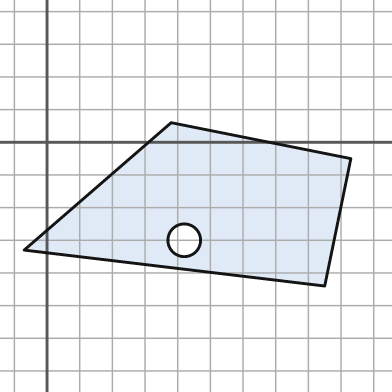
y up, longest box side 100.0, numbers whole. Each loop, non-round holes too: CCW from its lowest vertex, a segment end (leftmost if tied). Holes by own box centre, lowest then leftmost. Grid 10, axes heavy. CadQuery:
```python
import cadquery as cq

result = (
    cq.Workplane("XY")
    .moveTo(85.0, -44.0)
    .lineTo(93.0, -5.0)
    .lineTo(38.0, 6.0)
    .lineTo(-7.0, -33.0)
    .close()
    .moveTo(42.0, -30.0)
    .circle(5.0)
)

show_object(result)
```